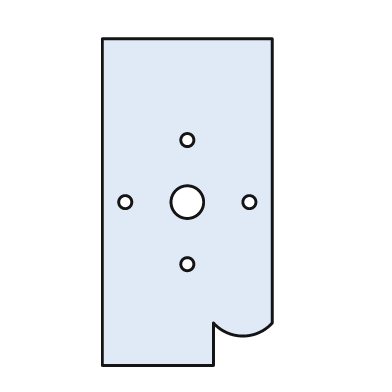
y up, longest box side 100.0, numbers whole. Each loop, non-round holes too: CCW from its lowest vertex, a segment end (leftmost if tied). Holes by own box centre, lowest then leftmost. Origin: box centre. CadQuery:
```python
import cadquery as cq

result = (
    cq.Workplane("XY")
    .moveTo(-26.0, -50.0)
    .lineTo(8.0, -50.0)
    .lineTo(8.0, -37.0)
    .threePointArc((17.0, -41.0), (26.0, -37.0))
    .lineTo(26.0, 50.0)
    .lineTo(-26.0, 50.0)
    .close()
    .moveTo(0.0, -19.0)
    .circle(2.0)
    .moveTo(-19.0, 0.0)
    .circle(2.0)
    .moveTo(0.0, 0.0)
    .circle(5.0)
    .moveTo(19.0, 0.0)
    .circle(2.0)
    .moveTo(0.0, 19.0)
    .circle(2.0)
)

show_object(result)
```